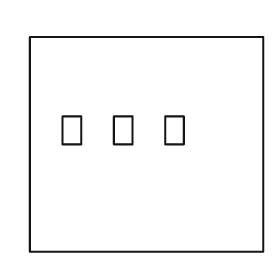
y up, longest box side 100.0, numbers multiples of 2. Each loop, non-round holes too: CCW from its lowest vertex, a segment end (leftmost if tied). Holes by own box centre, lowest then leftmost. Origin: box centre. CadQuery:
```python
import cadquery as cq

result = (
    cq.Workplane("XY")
    .moveTo(-50.0, -46.0)
    .lineTo(50.0, -46.0)
    .lineTo(50.0, 46.0)
    .lineTo(-50.0, 46.0)
    .close()
    .moveTo(-36.0, 0.0)
    .lineTo(-28.0, 0.0)
    .lineTo(-28.0, 12.0)
    .lineTo(-36.0, 12.0)
    .close()
    .moveTo(-14.0, 0.0)
    .lineTo(-6.0, 0.0)
    .lineTo(-6.0, 12.0)
    .lineTo(-14.0, 12.0)
    .close()
    .moveTo(8.0, 0.0)
    .lineTo(16.0, 0.0)
    .lineTo(16.0, 12.0)
    .lineTo(8.0, 12.0)
    .close()
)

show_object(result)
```